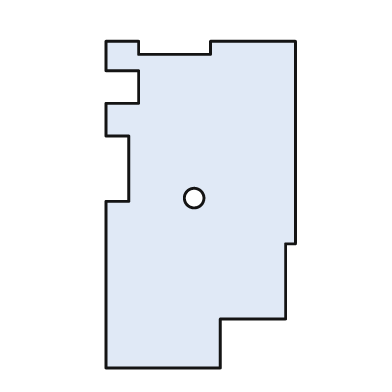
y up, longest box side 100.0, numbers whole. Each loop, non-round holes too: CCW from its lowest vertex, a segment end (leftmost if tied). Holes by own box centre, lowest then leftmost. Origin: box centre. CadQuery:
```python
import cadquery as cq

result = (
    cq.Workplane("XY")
    .moveTo(-29.0, -50.0)
    .lineTo(6.0, -50.0)
    .lineTo(6.0, -35.0)
    .lineTo(26.0, -35.0)
    .lineTo(26.0, -12.0)
    .lineTo(29.0, -12.0)
    .lineTo(29.0, 50.0)
    .lineTo(3.0, 50.0)
    .lineTo(3.0, 46.0)
    .lineTo(-19.0, 46.0)
    .lineTo(-19.0, 50.0)
    .lineTo(-29.0, 50.0)
    .lineTo(-29.0, 41.0)
    .lineTo(-19.0, 41.0)
    .lineTo(-19.0, 31.0)
    .lineTo(-29.0, 31.0)
    .lineTo(-29.0, 21.0)
    .lineTo(-22.0, 21.0)
    .lineTo(-22.0, 1.0)
    .lineTo(-29.0, 1.0)
    .close()
    .moveTo(-2.0, 2.0)
    .circle(3.0)
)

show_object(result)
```